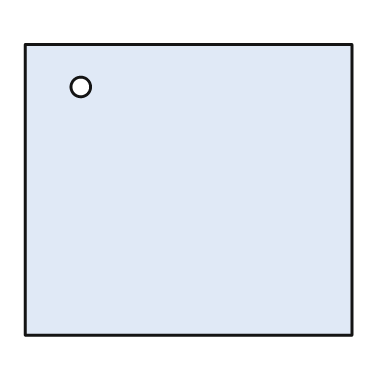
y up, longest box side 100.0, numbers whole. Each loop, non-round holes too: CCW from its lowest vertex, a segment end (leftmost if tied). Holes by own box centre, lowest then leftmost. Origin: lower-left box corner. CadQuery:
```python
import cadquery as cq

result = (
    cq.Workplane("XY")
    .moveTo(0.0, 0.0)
    .lineTo(100.0, 0.0)
    .lineTo(100.0, 89.0)
    .lineTo(0.0, 89.0)
    .close()
    .moveTo(17.0, 76.0)
    .circle(3.0)
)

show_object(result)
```